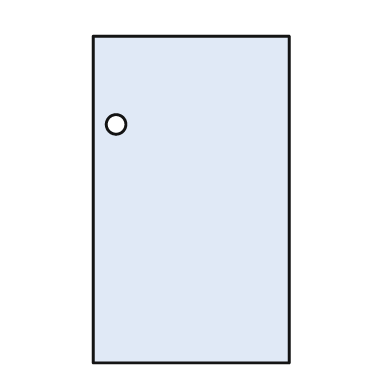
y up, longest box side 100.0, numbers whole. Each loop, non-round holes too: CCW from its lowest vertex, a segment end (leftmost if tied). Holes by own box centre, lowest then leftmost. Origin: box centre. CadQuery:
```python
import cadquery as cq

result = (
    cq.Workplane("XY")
    .moveTo(-30.0, -50.0)
    .lineTo(30.0, -50.0)
    .lineTo(30.0, 50.0)
    .lineTo(-30.0, 50.0)
    .close()
    .moveTo(-23.0, 23.0)
    .circle(3.0)
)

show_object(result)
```